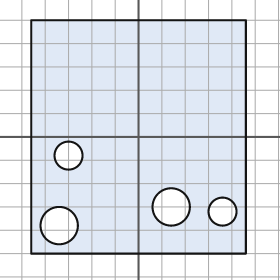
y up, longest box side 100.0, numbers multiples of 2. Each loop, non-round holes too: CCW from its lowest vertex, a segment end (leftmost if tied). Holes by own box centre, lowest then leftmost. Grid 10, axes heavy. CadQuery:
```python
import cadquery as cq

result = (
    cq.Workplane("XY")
    .moveTo(-46.0, -50.0)
    .lineTo(46.0, -50.0)
    .lineTo(46.0, 50.0)
    .lineTo(-46.0, 50.0)
    .close()
    .moveTo(-34.0, -38.0)
    .circle(8.0)
    .moveTo(36.0, -32.0)
    .circle(6.0)
    .moveTo(14.0, -30.0)
    .circle(8.0)
    .moveTo(-30.0, -8.0)
    .circle(6.0)
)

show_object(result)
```